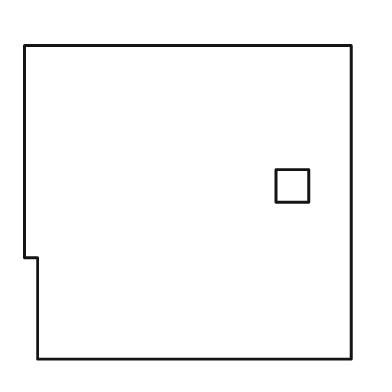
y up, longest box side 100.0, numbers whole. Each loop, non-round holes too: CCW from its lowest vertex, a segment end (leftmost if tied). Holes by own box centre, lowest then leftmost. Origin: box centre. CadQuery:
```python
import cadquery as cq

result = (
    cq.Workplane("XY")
    .moveTo(-46.0, -48.0)
    .lineTo(50.0, -48.0)
    .lineTo(50.0, 48.0)
    .lineTo(-50.0, 48.0)
    .lineTo(-50.0, -17.0)
    .lineTo(-46.0, -17.0)
    .close()
    .moveTo(27.0, 0.0)
    .lineTo(37.0, 0.0)
    .lineTo(37.0, 10.0)
    .lineTo(27.0, 10.0)
    .close()
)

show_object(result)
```